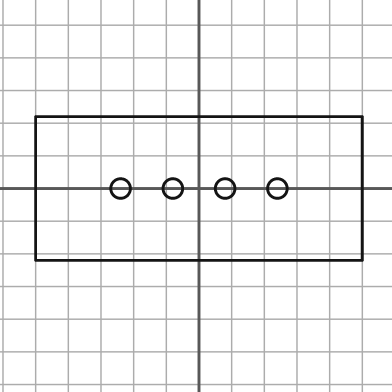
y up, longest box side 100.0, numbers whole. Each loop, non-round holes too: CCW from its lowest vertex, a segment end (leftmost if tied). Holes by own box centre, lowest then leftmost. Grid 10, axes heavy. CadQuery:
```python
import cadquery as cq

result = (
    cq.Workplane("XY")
    .moveTo(-50.0, -22.0)
    .lineTo(50.0, -22.0)
    .lineTo(50.0, 22.0)
    .lineTo(-50.0, 22.0)
    .close()
    .moveTo(-24.0, 0.0)
    .circle(3.0)
    .moveTo(-8.0, 0.0)
    .circle(3.0)
    .moveTo(8.0, 0.0)
    .circle(3.0)
    .moveTo(24.0, 0.0)
    .circle(3.0)
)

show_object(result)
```